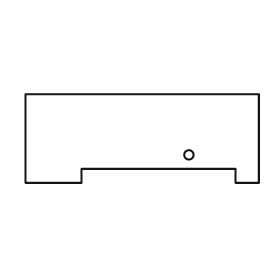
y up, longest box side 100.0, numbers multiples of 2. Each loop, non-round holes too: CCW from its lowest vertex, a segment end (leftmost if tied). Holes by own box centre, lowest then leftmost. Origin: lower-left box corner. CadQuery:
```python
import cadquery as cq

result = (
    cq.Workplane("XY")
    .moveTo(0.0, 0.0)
    .lineTo(24.0, 0.0)
    .lineTo(24.0, 6.0)
    .lineTo(90.0, 6.0)
    .lineTo(90.0, 0.0)
    .lineTo(100.0, 0.0)
    .lineTo(100.0, 38.0)
    .lineTo(0.0, 38.0)
    .close()
    .moveTo(70.0, 12.0)
    .circle(2.0)
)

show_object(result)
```